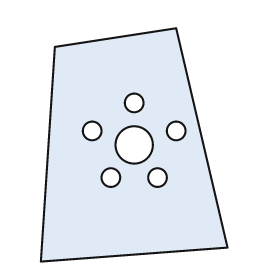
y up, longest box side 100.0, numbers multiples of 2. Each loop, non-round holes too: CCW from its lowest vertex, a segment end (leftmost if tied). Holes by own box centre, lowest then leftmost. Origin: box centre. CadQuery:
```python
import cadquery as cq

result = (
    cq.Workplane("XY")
    .moveTo(-40.0, -50.0)
    .lineTo(40.0, -44.0)
    .lineTo(18.0, 50.0)
    .lineTo(-34.0, 42.0)
    .close()
    .moveTo(-10.0, -14.0)
    .circle(4.0)
    .moveTo(10.0, -14.0)
    .circle(4.0)
    .moveTo(0.0, 0.0)
    .circle(8.0)
    .moveTo(-18.0, 6.0)
    .circle(4.0)
    .moveTo(18.0, 6.0)
    .circle(4.0)
    .moveTo(0.0, 18.0)
    .circle(4.0)
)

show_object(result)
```